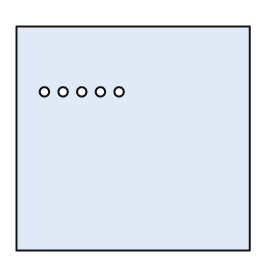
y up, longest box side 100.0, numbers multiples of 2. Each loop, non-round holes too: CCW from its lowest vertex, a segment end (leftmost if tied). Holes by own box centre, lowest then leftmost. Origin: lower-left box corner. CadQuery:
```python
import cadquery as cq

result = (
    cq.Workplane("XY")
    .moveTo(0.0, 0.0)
    .lineTo(100.0, 0.0)
    .lineTo(100.0, 96.0)
    .lineTo(0.0, 96.0)
    .close()
    .moveTo(12.0, 68.0)
    .circle(2.0)
    .moveTo(20.0, 68.0)
    .circle(2.0)
    .moveTo(28.0, 68.0)
    .circle(2.0)
    .moveTo(36.0, 68.0)
    .circle(2.0)
    .moveTo(44.0, 68.0)
    .circle(2.0)
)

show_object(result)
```